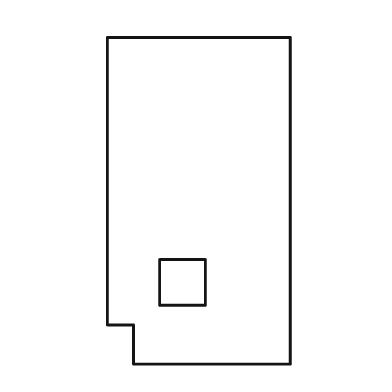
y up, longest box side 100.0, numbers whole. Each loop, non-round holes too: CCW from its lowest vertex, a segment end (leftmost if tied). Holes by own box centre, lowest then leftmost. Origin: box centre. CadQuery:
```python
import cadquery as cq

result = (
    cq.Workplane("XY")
    .moveTo(-20.0, -50.0)
    .lineTo(28.0, -50.0)
    .lineTo(28.0, 50.0)
    .lineTo(-28.0, 50.0)
    .lineTo(-28.0, -38.0)
    .lineTo(-20.0, -38.0)
    .close()
    .moveTo(-12.0, -32.0)
    .lineTo(2.0, -32.0)
    .lineTo(2.0, -18.0)
    .lineTo(-12.0, -18.0)
    .close()
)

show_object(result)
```